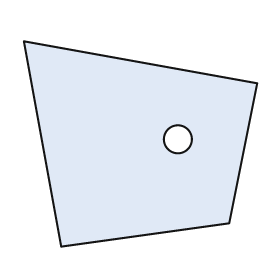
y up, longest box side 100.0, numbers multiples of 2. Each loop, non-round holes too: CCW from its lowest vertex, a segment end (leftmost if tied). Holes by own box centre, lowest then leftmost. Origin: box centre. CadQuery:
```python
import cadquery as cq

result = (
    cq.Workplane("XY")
    .moveTo(-34.0, -44.0)
    .lineTo(38.0, -34.0)
    .lineTo(50.0, 26.0)
    .lineTo(-50.0, 44.0)
    .close()
    .moveTo(16.0, 2.0)
    .circle(6.0)
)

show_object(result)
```